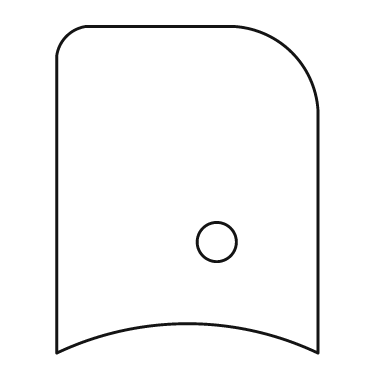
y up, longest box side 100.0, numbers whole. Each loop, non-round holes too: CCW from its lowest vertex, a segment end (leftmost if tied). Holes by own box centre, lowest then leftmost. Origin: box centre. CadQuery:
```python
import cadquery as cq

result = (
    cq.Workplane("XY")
    .moveTo(-40.0, -50.0)
    .threePointArc((0.0, -41.0), (40.0, -50.0))
    .lineTo(40.0, 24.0)
    .threePointArc((32.0, 42.0), (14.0, 50.0))
    .lineTo(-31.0, 50.0)
    .threePointArc((-37.0, 47.0), (-40.0, 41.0))
    .close()
    .moveTo(9.0, -16.0)
    .circle(6.0)
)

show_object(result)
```